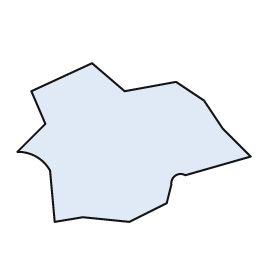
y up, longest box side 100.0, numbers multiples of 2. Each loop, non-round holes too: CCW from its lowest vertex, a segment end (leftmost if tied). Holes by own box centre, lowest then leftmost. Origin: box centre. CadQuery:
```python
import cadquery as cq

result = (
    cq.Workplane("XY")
    .moveTo(-34.0, -34.0)
    .lineTo(-22.0, -32.0)
    .lineTo(-2.0, -34.0)
    .lineTo(14.0, -26.0)
    .lineTo(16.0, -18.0)
    .threePointArc((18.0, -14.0), (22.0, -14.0))
    .lineTo(50.0, -6.0)
    .lineTo(38.0, 6.0)
    .lineTo(30.0, 18.0)
    .lineTo(18.0, 26.0)
    .lineTo(-4.0, 22.0)
    .lineTo(-18.0, 34.0)
    .lineTo(-44.0, 22.0)
    .lineTo(-38.0, 8.0)
    .lineTo(-50.0, -4.0)
    .threePointArc((-42.0, -6.0), (-36.0, -12.0))
    .close()
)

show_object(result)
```